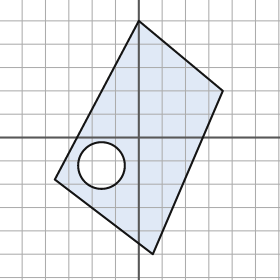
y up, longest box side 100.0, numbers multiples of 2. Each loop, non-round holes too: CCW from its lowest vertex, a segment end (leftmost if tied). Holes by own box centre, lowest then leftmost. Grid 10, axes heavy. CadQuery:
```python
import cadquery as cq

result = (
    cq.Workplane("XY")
    .moveTo(6.0, -50.0)
    .lineTo(36.0, 20.0)
    .lineTo(0.0, 50.0)
    .lineTo(-36.0, -18.0)
    .close()
    .moveTo(-16.0, -12.0)
    .circle(10.0)
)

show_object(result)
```